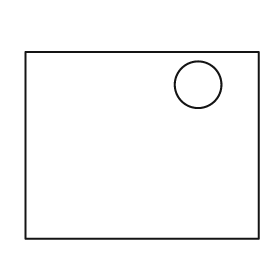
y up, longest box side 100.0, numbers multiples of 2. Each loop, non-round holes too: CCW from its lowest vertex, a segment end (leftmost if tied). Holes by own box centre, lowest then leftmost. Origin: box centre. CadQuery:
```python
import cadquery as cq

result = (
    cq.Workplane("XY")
    .moveTo(-50.0, -40.0)
    .lineTo(50.0, -40.0)
    .lineTo(50.0, 40.0)
    .lineTo(-50.0, 40.0)
    .close()
    .moveTo(24.0, 26.0)
    .circle(10.0)
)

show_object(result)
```